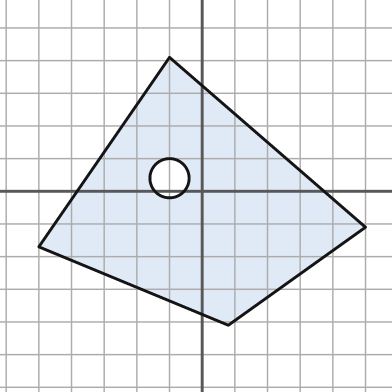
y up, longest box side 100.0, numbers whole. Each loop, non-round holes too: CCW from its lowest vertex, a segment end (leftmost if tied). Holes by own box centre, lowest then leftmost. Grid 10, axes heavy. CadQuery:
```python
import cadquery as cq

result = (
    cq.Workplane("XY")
    .moveTo(8.0, -41.0)
    .lineTo(50.0, -11.0)
    .lineTo(-10.0, 41.0)
    .lineTo(-50.0, -17.0)
    .close()
    .moveTo(-10.0, 4.0)
    .circle(6.0)
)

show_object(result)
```